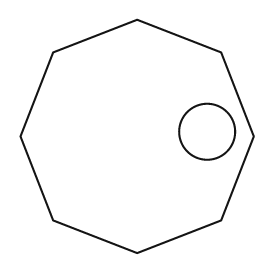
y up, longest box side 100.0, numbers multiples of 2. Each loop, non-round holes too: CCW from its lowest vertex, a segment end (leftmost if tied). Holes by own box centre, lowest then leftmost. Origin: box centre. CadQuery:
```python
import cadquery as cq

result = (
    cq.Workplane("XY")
    .moveTo(0.0, -50.0)
    .lineTo(36.0, -36.0)
    .lineTo(50.0, 0.0)
    .lineTo(36.0, 36.0)
    .lineTo(0.0, 50.0)
    .lineTo(-36.0, 36.0)
    .lineTo(-50.0, 0.0)
    .lineTo(-36.0, -36.0)
    .close()
    .moveTo(30.0, 2.0)
    .circle(12.0)
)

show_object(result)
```